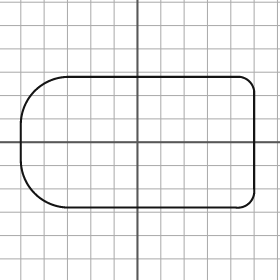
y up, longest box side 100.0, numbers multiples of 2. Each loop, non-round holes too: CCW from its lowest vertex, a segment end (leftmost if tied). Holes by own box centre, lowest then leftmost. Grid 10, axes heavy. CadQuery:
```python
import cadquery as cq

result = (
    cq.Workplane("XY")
    .moveTo(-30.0, -28.0)
    .lineTo(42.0, -28.0)
    .threePointArc((48.0, -26.0), (50.0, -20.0))
    .lineTo(50.0, 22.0)
    .threePointArc((48.0, 26.0), (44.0, 28.0))
    .lineTo(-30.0, 28.0)
    .threePointArc((-44.0, 22.0), (-50.0, 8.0))
    .lineTo(-50.0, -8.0)
    .threePointArc((-44.0, -22.0), (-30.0, -28.0))
    .close()
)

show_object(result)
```